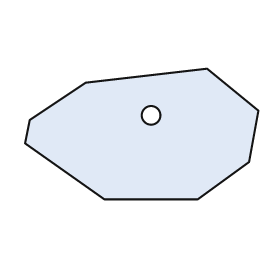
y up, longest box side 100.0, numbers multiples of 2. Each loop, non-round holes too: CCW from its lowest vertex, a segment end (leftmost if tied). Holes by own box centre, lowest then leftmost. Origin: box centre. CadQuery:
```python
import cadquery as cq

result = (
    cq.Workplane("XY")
    .moveTo(-16.0, -28.0)
    .lineTo(24.0, -28.0)
    .lineTo(46.0, -12.0)
    .lineTo(50.0, 10.0)
    .lineTo(28.0, 28.0)
    .lineTo(-24.0, 22.0)
    .lineTo(-48.0, 6.0)
    .lineTo(-50.0, -4.0)
    .close()
    .moveTo(4.0, 8.0)
    .circle(4.0)
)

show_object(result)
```